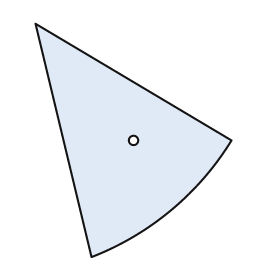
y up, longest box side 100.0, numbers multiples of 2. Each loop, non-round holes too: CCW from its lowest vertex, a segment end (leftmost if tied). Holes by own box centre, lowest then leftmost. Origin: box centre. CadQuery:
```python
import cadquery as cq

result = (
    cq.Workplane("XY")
    .moveTo(-18.0, -50.0)
    .threePointArc((16.0, -30.0), (42.0, 0.0))
    .lineTo(-42.0, 50.0)
    .close()
    .moveTo(0.0, 0.0)
    .circle(2.0)
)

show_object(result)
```